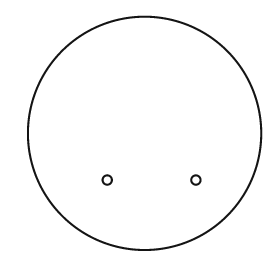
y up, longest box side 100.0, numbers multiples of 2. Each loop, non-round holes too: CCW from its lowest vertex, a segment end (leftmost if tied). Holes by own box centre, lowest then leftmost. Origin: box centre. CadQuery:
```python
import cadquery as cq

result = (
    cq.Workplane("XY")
    .moveTo(0.0, 0.0)
    .circle(50.0)
    .moveTo(-16.0, -20.0)
    .circle(2.0)
    .moveTo(22.0, -20.0)
    .circle(2.0)
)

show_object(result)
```